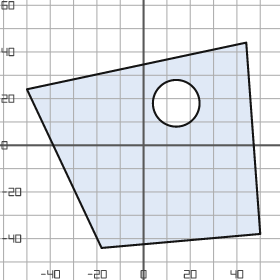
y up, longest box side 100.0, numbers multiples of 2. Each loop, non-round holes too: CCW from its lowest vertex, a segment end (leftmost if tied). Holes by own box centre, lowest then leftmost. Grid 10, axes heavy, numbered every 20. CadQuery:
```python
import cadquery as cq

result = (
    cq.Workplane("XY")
    .moveTo(-18.0, -44.0)
    .lineTo(50.0, -38.0)
    .lineTo(44.0, 44.0)
    .lineTo(-50.0, 24.0)
    .close()
    .moveTo(14.0, 18.0)
    .circle(10.0)
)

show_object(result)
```